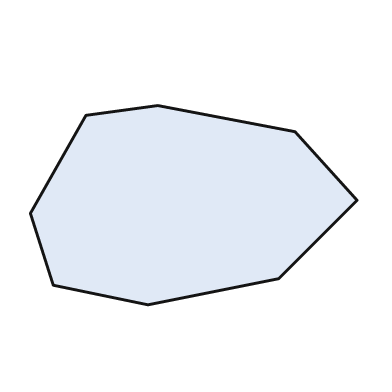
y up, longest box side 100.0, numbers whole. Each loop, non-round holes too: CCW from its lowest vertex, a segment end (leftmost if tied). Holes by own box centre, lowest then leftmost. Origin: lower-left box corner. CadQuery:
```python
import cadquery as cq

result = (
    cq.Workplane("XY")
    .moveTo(36.0, 0.0)
    .lineTo(76.0, 8.0)
    .lineTo(100.0, 32.0)
    .lineTo(81.0, 53.0)
    .lineTo(39.0, 61.0)
    .lineTo(17.0, 58.0)
    .lineTo(0.0, 28.0)
    .lineTo(7.0, 6.0)
    .close()
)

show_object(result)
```